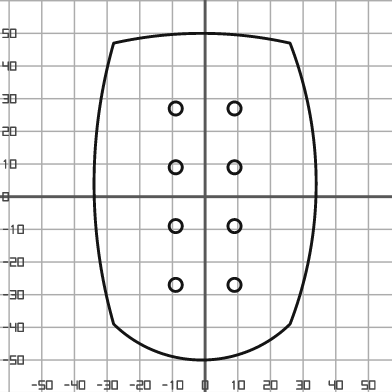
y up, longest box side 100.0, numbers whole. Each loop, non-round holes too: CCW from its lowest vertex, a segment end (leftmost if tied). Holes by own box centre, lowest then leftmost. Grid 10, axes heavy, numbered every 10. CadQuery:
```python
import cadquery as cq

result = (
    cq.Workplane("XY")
    .moveTo(-28.0, -39.0)
    .threePointArc((-1.0, -50.0), (26.0, -39.0))
    .threePointArc((34.0, 4.0), (26.0, 47.0))
    .threePointArc((-1.0, 50.0), (-28.0, 47.0))
    .threePointArc((-34.0, 4.0), (-28.0, -39.0))
    .close()
    .moveTo(-9.0, -27.0)
    .circle(2.0)
    .moveTo(9.0, -27.0)
    .circle(2.0)
    .moveTo(-9.0, -9.0)
    .circle(2.0)
    .moveTo(9.0, -9.0)
    .circle(2.0)
    .moveTo(-9.0, 9.0)
    .circle(2.0)
    .moveTo(9.0, 9.0)
    .circle(2.0)
    .moveTo(-9.0, 27.0)
    .circle(2.0)
    .moveTo(9.0, 27.0)
    .circle(2.0)
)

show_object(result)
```